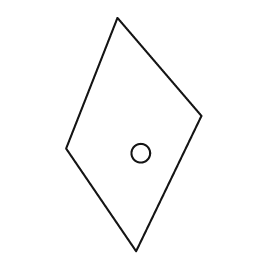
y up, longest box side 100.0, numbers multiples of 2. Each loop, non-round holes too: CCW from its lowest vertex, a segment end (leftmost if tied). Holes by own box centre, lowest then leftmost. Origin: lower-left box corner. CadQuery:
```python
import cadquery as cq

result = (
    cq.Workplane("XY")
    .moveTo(30.0, 0.0)
    .lineTo(58.0, 58.0)
    .lineTo(22.0, 100.0)
    .lineTo(0.0, 44.0)
    .close()
    .moveTo(32.0, 42.0)
    .circle(4.0)
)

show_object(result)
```